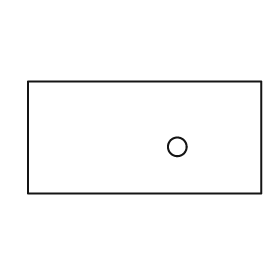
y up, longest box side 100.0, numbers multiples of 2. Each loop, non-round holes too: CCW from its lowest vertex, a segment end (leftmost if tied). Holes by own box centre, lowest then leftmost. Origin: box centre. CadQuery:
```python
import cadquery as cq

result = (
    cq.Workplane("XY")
    .moveTo(-50.0, -24.0)
    .lineTo(50.0, -24.0)
    .lineTo(50.0, 24.0)
    .lineTo(-50.0, 24.0)
    .close()
    .moveTo(14.0, -4.0)
    .circle(4.0)
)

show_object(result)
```